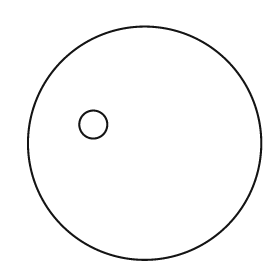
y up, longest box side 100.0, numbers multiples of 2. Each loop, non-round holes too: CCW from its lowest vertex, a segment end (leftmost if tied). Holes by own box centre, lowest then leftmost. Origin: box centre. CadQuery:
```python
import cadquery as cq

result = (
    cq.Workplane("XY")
    .moveTo(0.0, 0.0)
    .circle(50.0)
    .moveTo(-22.0, 8.0)
    .circle(6.0)
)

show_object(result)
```